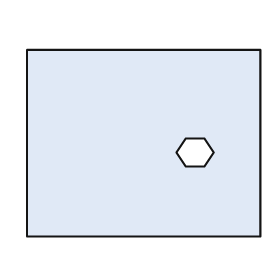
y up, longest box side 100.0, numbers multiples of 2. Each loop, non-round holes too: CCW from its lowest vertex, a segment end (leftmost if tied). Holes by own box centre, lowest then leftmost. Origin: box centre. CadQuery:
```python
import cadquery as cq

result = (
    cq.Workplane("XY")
    .moveTo(-50.0, -40.0)
    .lineTo(50.0, -40.0)
    .lineTo(50.0, 40.0)
    .lineTo(-50.0, 40.0)
    .close()
    .moveTo(18.0, -10.0)
    .lineTo(26.0, -10.0)
    .lineTo(30.0, -4.0)
    .lineTo(26.0, 2.0)
    .lineTo(18.0, 2.0)
    .lineTo(14.0, -4.0)
    .close()
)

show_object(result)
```